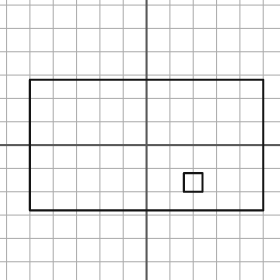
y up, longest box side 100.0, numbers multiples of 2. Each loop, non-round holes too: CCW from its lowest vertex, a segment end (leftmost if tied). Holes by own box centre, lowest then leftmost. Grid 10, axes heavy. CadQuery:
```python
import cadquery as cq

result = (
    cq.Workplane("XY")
    .moveTo(-50.0, -28.0)
    .lineTo(50.0, -28.0)
    .lineTo(50.0, 28.0)
    .lineTo(-50.0, 28.0)
    .close()
    .moveTo(16.0, -20.0)
    .lineTo(24.0, -20.0)
    .lineTo(24.0, -12.0)
    .lineTo(16.0, -12.0)
    .close()
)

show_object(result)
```